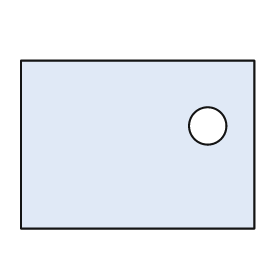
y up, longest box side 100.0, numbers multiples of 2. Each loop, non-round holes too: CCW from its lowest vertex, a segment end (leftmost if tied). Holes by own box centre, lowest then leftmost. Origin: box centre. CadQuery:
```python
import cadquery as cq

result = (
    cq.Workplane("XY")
    .moveTo(-50.0, -36.0)
    .lineTo(50.0, -36.0)
    .lineTo(50.0, 36.0)
    .lineTo(-50.0, 36.0)
    .close()
    .moveTo(30.0, 8.0)
    .circle(8.0)
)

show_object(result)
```